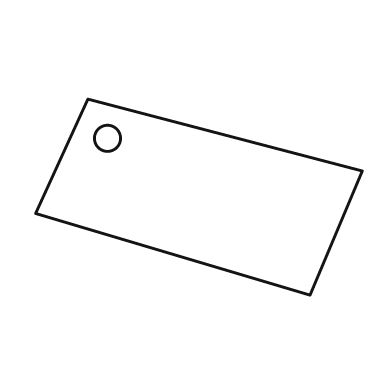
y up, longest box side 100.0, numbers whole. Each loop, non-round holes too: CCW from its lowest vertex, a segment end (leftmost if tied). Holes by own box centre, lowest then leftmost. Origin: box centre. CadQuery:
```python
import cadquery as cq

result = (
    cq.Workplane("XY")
    .moveTo(34.0, -30.0)
    .lineTo(50.0, 8.0)
    .lineTo(-34.0, 30.0)
    .lineTo(-50.0, -5.0)
    .close()
    .moveTo(-28.0, 18.0)
    .circle(4.0)
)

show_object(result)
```